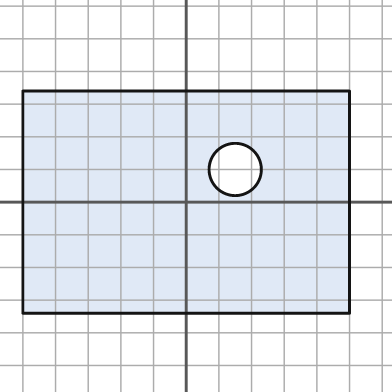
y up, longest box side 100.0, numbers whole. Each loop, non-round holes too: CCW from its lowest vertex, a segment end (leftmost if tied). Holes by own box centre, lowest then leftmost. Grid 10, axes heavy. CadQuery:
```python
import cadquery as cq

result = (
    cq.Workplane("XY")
    .moveTo(-50.0, -34.0)
    .lineTo(50.0, -34.0)
    .lineTo(50.0, 34.0)
    .lineTo(-50.0, 34.0)
    .close()
    .moveTo(15.0, 10.0)
    .circle(8.0)
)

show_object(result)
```